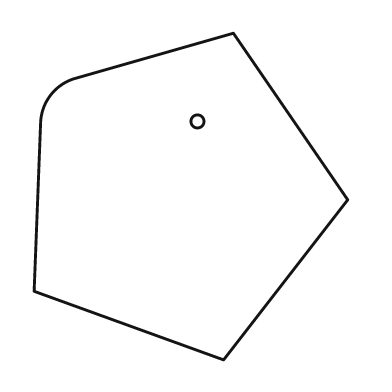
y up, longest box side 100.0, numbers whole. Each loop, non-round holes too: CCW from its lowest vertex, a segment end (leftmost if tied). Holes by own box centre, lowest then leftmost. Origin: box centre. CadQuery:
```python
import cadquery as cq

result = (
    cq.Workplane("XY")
    .moveTo(10.0, -50.0)
    .lineTo(48.0, -1.0)
    .lineTo(13.0, 50.0)
    .lineTo(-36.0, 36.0)
    .threePointArc((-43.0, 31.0), (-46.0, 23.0))
    .lineTo(-48.0, -29.0)
    .close()
    .moveTo(2.0, 23.0)
    .circle(2.0)
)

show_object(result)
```